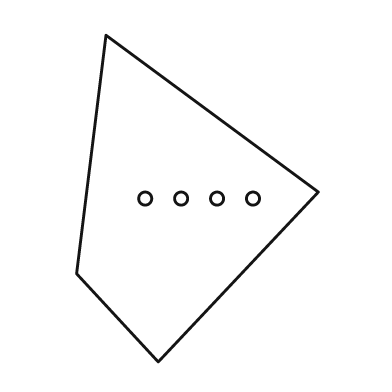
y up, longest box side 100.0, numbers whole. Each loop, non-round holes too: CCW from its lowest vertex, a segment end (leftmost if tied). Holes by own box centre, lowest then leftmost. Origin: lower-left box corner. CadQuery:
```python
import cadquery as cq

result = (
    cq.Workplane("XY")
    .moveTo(25.0, 0.0)
    .lineTo(74.0, 52.0)
    .lineTo(9.0, 100.0)
    .lineTo(0.0, 27.0)
    .close()
    .moveTo(21.0, 50.0)
    .circle(2.0)
    .moveTo(32.0, 50.0)
    .circle(2.0)
    .moveTo(43.0, 50.0)
    .circle(2.0)
    .moveTo(54.0, 50.0)
    .circle(2.0)
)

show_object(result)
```